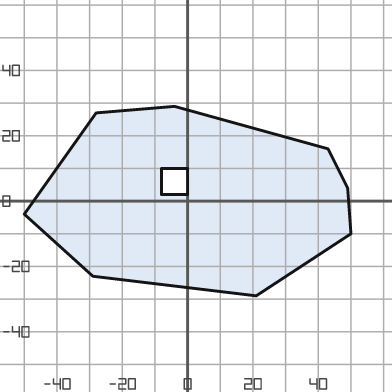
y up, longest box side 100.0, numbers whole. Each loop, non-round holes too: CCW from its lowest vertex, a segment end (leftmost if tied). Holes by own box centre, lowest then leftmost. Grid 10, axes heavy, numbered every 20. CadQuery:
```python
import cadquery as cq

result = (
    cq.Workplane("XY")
    .moveTo(21.0, -29.0)
    .lineTo(50.0, -10.0)
    .lineTo(49.0, 4.0)
    .lineTo(43.0, 16.0)
    .lineTo(-4.0, 29.0)
    .lineTo(-28.0, 27.0)
    .lineTo(-50.0, -4.0)
    .lineTo(-29.0, -23.0)
    .close()
    .moveTo(-8.0, 2.0)
    .lineTo(0.0, 2.0)
    .lineTo(0.0, 10.0)
    .lineTo(-8.0, 10.0)
    .close()
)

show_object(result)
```